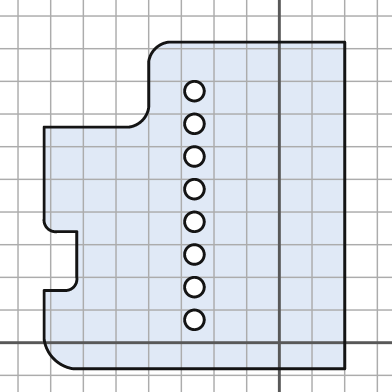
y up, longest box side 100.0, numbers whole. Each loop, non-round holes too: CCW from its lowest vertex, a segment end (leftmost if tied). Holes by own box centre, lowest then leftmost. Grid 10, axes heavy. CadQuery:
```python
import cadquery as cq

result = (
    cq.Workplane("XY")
    .moveTo(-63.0, -8.0)
    .lineTo(20.0, -8.0)
    .lineTo(20.0, 92.0)
    .lineTo(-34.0, 92.0)
    .threePointArc((-38.0, 90.0), (-40.0, 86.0))
    .lineTo(-40.0, 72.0)
    .threePointArc((-42.0, 68.0), (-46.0, 66.0))
    .lineTo(-72.0, 66.0)
    .lineTo(-72.0, 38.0)
    .threePointArc((-71.0, 35.0), (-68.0, 34.0))
    .lineTo(-62.0, 34.0)
    .lineTo(-62.0, 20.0)
    .threePointArc((-63.0, 17.0), (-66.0, 16.0))
    .lineTo(-72.0, 16.0)
    .lineTo(-72.0, 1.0)
    .threePointArc((-69.0, -5.0), (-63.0, -8.0))
    .close()
    .moveTo(-26.0, 7.0)
    .circle(3.0)
    .moveTo(-26.0, 17.0)
    .circle(3.0)
    .moveTo(-26.0, 27.0)
    .circle(3.0)
    .moveTo(-26.0, 37.0)
    .circle(3.0)
    .moveTo(-26.0, 47.0)
    .circle(3.0)
    .moveTo(-26.0, 57.0)
    .circle(3.0)
    .moveTo(-26.0, 67.0)
    .circle(3.0)
    .moveTo(-26.0, 77.0)
    .circle(3.0)
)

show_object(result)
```